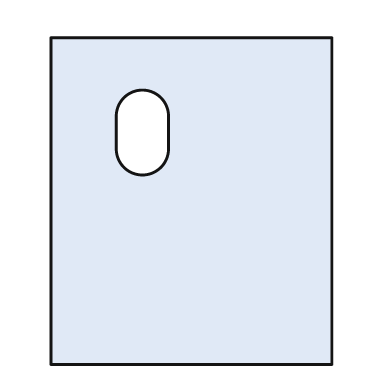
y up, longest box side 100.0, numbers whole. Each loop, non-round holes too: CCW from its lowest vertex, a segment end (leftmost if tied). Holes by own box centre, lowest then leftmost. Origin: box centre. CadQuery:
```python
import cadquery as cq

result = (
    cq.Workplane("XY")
    .moveTo(-43.0, -50.0)
    .lineTo(43.0, -50.0)
    .lineTo(43.0, 50.0)
    .lineTo(-43.0, 50.0)
    .close()
    .moveTo(-23.0, 16.0)
    .threePointArc((-15.0, 8.0), (-7.0, 16.0))
    .lineTo(-7.0, 26.0)
    .threePointArc((-15.0, 34.0), (-23.0, 26.0))
    .close()
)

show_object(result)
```